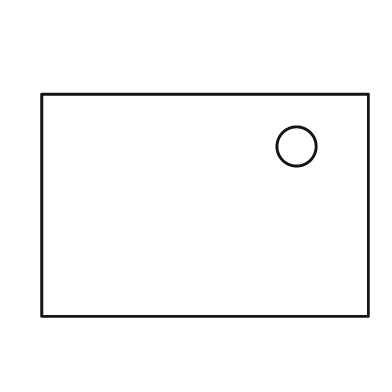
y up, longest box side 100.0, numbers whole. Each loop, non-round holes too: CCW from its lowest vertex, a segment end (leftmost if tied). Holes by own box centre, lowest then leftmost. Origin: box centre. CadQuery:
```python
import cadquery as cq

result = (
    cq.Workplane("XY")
    .moveTo(-50.0, -34.0)
    .lineTo(50.0, -34.0)
    .lineTo(50.0, 34.0)
    .lineTo(-50.0, 34.0)
    .close()
    .moveTo(28.0, 18.0)
    .circle(6.0)
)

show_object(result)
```